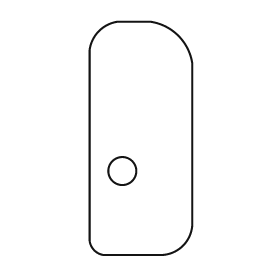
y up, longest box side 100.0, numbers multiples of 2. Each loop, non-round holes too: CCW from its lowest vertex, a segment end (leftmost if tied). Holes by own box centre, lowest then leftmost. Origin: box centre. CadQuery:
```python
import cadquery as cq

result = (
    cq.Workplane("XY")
    .moveTo(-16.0, -50.0)
    .lineTo(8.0, -50.0)
    .threePointArc((18.0, -46.0), (22.0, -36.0))
    .lineTo(22.0, 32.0)
    .threePointArc((16.0, 44.0), (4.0, 50.0))
    .lineTo(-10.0, 50.0)
    .threePointArc((-18.0, 46.0), (-22.0, 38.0))
    .lineTo(-22.0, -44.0)
    .threePointArc((-20.0, -48.0), (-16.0, -50.0))
    .close()
    .moveTo(-8.0, -14.0)
    .circle(6.0)
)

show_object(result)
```